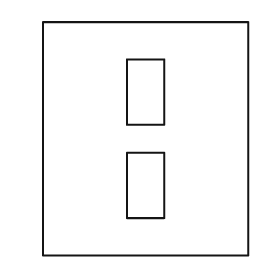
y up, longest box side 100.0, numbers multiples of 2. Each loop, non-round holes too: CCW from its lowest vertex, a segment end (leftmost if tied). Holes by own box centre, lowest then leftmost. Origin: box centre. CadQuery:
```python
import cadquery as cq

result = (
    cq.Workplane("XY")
    .moveTo(-44.0, -50.0)
    .lineTo(44.0, -50.0)
    .lineTo(44.0, 50.0)
    .lineTo(-44.0, 50.0)
    .close()
    .moveTo(-8.0, -34.0)
    .lineTo(8.0, -34.0)
    .lineTo(8.0, -6.0)
    .lineTo(-8.0, -6.0)
    .close()
    .moveTo(-8.0, 6.0)
    .lineTo(8.0, 6.0)
    .lineTo(8.0, 34.0)
    .lineTo(-8.0, 34.0)
    .close()
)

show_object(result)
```